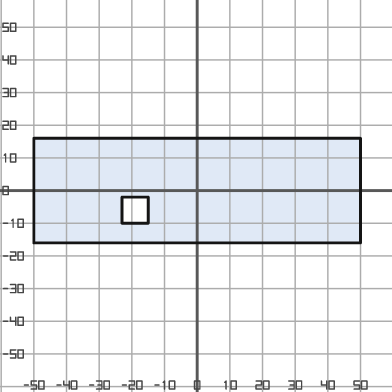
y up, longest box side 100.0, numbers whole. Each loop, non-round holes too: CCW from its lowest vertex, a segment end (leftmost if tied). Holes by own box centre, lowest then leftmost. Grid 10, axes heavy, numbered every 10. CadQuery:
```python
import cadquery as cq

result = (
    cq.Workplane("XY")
    .moveTo(-50.0, -16.0)
    .lineTo(50.0, -16.0)
    .lineTo(50.0, 16.0)
    .lineTo(-50.0, 16.0)
    .close()
    .moveTo(-23.0, -10.0)
    .lineTo(-15.0, -10.0)
    .lineTo(-15.0, -2.0)
    .lineTo(-23.0, -2.0)
    .close()
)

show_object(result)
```